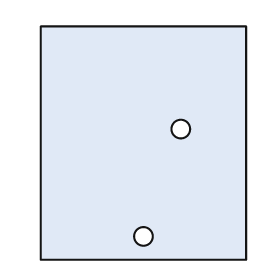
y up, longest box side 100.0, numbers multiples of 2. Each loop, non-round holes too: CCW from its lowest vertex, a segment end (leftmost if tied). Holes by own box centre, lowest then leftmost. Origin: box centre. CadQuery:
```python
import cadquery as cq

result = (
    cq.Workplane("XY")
    .moveTo(-44.0, -50.0)
    .lineTo(44.0, -50.0)
    .lineTo(44.0, 50.0)
    .lineTo(-44.0, 50.0)
    .close()
    .moveTo(0.0, -40.0)
    .circle(4.0)
    .moveTo(16.0, 6.0)
    .circle(4.0)
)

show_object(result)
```